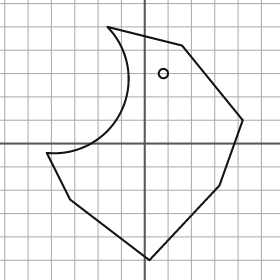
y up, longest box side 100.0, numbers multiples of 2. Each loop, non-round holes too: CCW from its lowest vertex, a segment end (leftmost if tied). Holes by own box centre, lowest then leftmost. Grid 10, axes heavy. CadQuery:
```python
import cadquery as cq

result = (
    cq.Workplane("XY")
    .moveTo(2.0, -50.0)
    .lineTo(32.0, -18.0)
    .lineTo(42.0, 10.0)
    .lineTo(16.0, 42.0)
    .lineTo(-16.0, 50.0)
    .threePointArc((-10.0, 14.0), (-42.0, -4.0))
    .lineTo(-32.0, -24.0)
    .close()
    .moveTo(8.0, 30.0)
    .circle(2.0)
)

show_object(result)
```